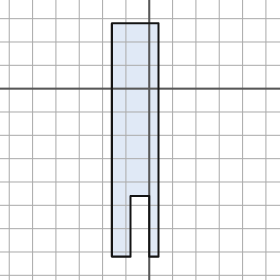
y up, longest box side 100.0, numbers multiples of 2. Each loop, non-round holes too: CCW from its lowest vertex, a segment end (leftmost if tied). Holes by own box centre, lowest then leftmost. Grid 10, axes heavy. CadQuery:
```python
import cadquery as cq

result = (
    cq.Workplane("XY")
    .moveTo(-16.0, -72.0)
    .lineTo(-8.0, -72.0)
    .lineTo(-8.0, -46.0)
    .lineTo(0.0, -46.0)
    .lineTo(0.0, -72.0)
    .lineTo(4.0, -72.0)
    .lineTo(4.0, 28.0)
    .lineTo(-16.0, 28.0)
    .close()
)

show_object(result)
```